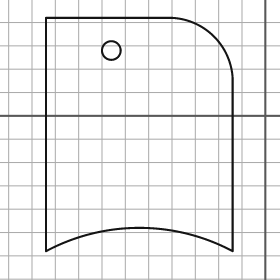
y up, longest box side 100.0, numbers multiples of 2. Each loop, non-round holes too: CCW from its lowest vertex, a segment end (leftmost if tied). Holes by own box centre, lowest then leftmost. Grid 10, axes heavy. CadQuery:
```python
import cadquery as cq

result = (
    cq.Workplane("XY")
    .moveTo(-94.0, -58.0)
    .threePointArc((-54.0, -48.0), (-14.0, -58.0))
    .lineTo(-14.0, 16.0)
    .threePointArc((-22.0, 34.0), (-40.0, 42.0))
    .lineTo(-94.0, 42.0)
    .close()
    .moveTo(-66.0, 28.0)
    .circle(4.0)
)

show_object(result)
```